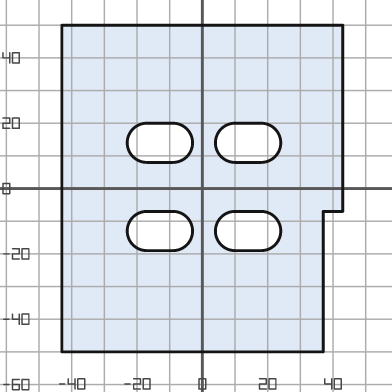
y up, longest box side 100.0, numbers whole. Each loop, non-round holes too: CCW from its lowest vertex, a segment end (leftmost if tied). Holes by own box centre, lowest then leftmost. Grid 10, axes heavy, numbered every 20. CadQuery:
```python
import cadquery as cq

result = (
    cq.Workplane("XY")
    .moveTo(-43.0, -50.0)
    .lineTo(37.0, -50.0)
    .lineTo(37.0, -7.0)
    .lineTo(43.0, -7.0)
    .lineTo(43.0, 50.0)
    .lineTo(-43.0, 50.0)
    .close()
    .moveTo(-17.0, -19.0)
    .lineTo(-9.0, -19.0)
    .threePointArc((-3.0, -13.0), (-9.0, -7.0))
    .lineTo(-17.0, -7.0)
    .threePointArc((-23.0, -13.0), (-17.0, -19.0))
    .close()
    .moveTo(10.0, -19.0)
    .lineTo(18.0, -19.0)
    .threePointArc((24.0, -13.0), (18.0, -7.0))
    .lineTo(10.0, -7.0)
    .threePointArc((4.0, -13.0), (10.0, -19.0))
    .close()
    .moveTo(-17.0, 8.0)
    .lineTo(-9.0, 8.0)
    .threePointArc((-3.0, 14.0), (-9.0, 20.0))
    .lineTo(-17.0, 20.0)
    .threePointArc((-23.0, 14.0), (-17.0, 8.0))
    .close()
    .moveTo(10.0, 8.0)
    .lineTo(18.0, 8.0)
    .threePointArc((24.0, 14.0), (18.0, 20.0))
    .lineTo(10.0, 20.0)
    .threePointArc((4.0, 14.0), (10.0, 8.0))
    .close()
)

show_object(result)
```